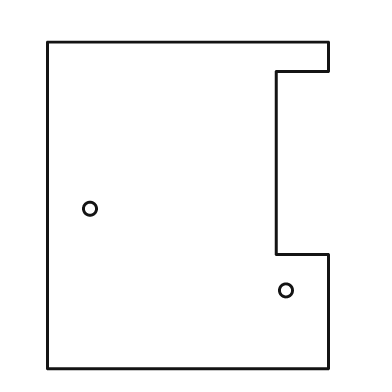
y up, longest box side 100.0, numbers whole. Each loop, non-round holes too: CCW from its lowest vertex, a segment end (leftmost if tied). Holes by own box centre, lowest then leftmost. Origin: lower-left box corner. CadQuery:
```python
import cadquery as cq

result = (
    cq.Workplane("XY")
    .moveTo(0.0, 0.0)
    .lineTo(86.0, 0.0)
    .lineTo(86.0, 35.0)
    .lineTo(70.0, 35.0)
    .lineTo(70.0, 91.0)
    .lineTo(86.0, 91.0)
    .lineTo(86.0, 100.0)
    .lineTo(0.0, 100.0)
    .close()
    .moveTo(73.0, 24.0)
    .circle(2.0)
    .moveTo(13.0, 49.0)
    .circle(2.0)
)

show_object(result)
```